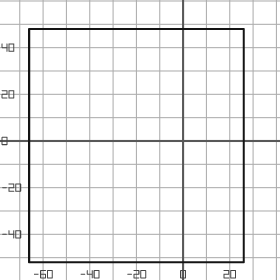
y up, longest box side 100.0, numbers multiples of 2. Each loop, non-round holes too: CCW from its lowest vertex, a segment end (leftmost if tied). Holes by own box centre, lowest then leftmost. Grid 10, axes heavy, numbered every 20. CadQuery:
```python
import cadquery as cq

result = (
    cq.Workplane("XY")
    .moveTo(-66.0, -52.0)
    .lineTo(26.0, -52.0)
    .lineTo(26.0, 48.0)
    .lineTo(-66.0, 48.0)
    .close()
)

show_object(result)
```